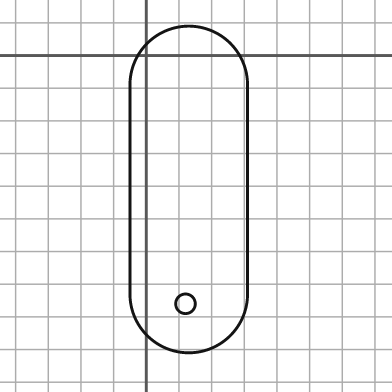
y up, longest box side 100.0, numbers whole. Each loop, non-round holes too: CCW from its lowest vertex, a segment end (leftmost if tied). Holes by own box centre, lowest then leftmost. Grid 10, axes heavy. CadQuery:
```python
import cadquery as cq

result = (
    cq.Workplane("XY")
    .moveTo(-5.0, -73.0)
    .threePointArc((13.0, -91.0), (31.0, -73.0))
    .lineTo(31.0, -9.0)
    .threePointArc((13.0, 9.0), (-5.0, -9.0))
    .close()
    .moveTo(12.0, -76.0)
    .circle(3.0)
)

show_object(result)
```